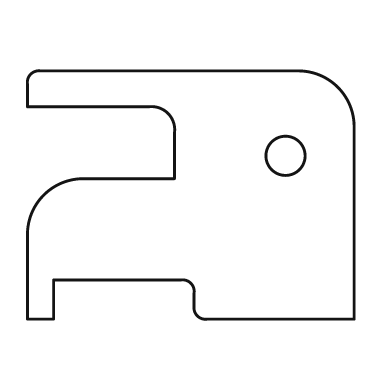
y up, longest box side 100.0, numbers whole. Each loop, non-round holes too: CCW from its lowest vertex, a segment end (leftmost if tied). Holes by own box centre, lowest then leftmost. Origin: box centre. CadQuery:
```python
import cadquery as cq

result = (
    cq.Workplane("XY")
    .moveTo(-50.0, -38.0)
    .lineTo(-42.0, -38.0)
    .lineTo(-42.0, -26.0)
    .lineTo(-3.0, -26.0)
    .threePointArc((0.0, -27.0), (1.0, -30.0))
    .lineTo(1.0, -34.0)
    .threePointArc((2.0, -37.0), (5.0, -38.0))
    .lineTo(50.0, -38.0)
    .lineTo(50.0, 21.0)
    .threePointArc((45.0, 33.0), (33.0, 38.0))
    .lineTo(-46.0, 38.0)
    .threePointArc((-49.0, 37.0), (-50.0, 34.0))
    .lineTo(-50.0, 27.0)
    .lineTo(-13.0, 27.0)
    .threePointArc((-7.0, 25.0), (-5.0, 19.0))
    .lineTo(-5.0, 5.0)
    .lineTo(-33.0, 5.0)
    .threePointArc((-45.0, 0.0), (-50.0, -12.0))
    .close()
    .moveTo(29.0, 12.0)
    .circle(6.0)
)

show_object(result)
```